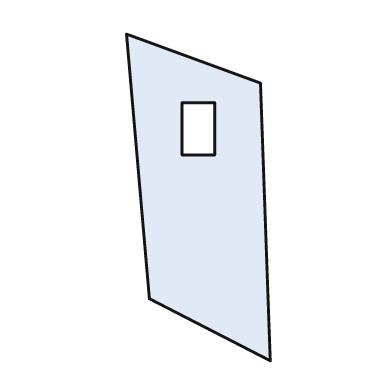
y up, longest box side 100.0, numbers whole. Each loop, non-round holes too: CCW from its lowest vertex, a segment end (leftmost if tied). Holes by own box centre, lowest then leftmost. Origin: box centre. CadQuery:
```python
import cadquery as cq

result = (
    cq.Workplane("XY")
    .moveTo(22.0, -50.0)
    .lineTo(19.0, 35.0)
    .lineTo(-22.0, 50.0)
    .lineTo(-15.0, -31.0)
    .close()
    .moveTo(-5.0, 13.0)
    .lineTo(5.0, 13.0)
    .lineTo(5.0, 29.0)
    .lineTo(-5.0, 29.0)
    .close()
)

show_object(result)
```